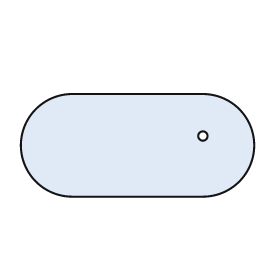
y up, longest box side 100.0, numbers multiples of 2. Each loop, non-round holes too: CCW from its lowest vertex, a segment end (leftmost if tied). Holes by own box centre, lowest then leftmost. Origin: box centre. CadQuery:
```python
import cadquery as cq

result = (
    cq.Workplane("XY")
    .moveTo(-28.0, -22.0)
    .lineTo(28.0, -22.0)
    .threePointArc((50.0, 0.0), (28.0, 22.0))
    .lineTo(-28.0, 22.0)
    .threePointArc((-50.0, 0.0), (-28.0, -22.0))
    .close()
    .moveTo(28.0, 4.0)
    .circle(2.0)
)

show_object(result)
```